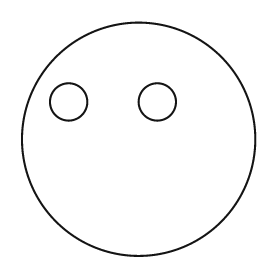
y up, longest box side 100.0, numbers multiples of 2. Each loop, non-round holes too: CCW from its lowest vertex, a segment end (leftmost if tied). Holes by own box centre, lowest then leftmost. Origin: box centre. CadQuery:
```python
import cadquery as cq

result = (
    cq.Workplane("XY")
    .moveTo(0.0, 0.0)
    .circle(50.0)
    .moveTo(-30.0, 16.0)
    .circle(8.0)
    .moveTo(8.0, 16.0)
    .circle(8.0)
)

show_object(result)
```